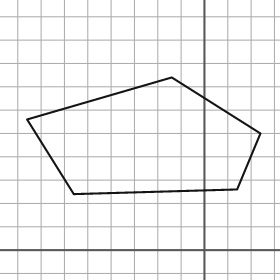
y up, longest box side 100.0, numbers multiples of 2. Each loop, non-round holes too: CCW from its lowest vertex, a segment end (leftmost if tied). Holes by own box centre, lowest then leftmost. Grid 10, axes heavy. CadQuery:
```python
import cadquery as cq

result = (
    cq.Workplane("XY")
    .moveTo(-56.0, 24.0)
    .lineTo(14.0, 26.0)
    .lineTo(24.0, 50.0)
    .lineTo(-14.0, 74.0)
    .lineTo(-76.0, 56.0)
    .close()
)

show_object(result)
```